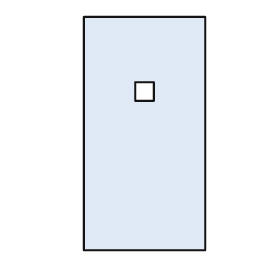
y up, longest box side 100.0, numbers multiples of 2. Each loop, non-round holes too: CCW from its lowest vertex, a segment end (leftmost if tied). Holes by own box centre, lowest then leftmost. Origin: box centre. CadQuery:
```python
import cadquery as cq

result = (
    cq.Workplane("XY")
    .moveTo(-26.0, -50.0)
    .lineTo(26.0, -50.0)
    .lineTo(26.0, 50.0)
    .lineTo(-26.0, 50.0)
    .close()
    .moveTo(-4.0, 14.0)
    .lineTo(4.0, 14.0)
    .lineTo(4.0, 22.0)
    .lineTo(-4.0, 22.0)
    .close()
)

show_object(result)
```